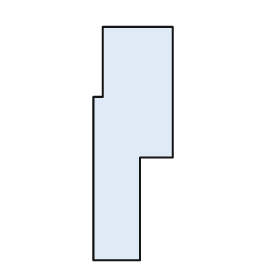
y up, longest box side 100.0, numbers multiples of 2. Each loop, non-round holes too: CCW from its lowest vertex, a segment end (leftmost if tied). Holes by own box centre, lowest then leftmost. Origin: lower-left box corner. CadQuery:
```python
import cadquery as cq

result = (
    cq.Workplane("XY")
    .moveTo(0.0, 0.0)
    .lineTo(20.0, 0.0)
    .lineTo(20.0, 44.0)
    .lineTo(34.0, 44.0)
    .lineTo(34.0, 100.0)
    .lineTo(4.0, 100.0)
    .lineTo(4.0, 70.0)
    .lineTo(0.0, 70.0)
    .close()
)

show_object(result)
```